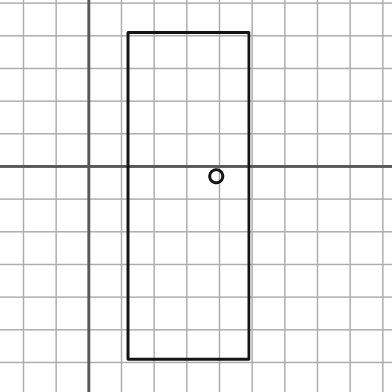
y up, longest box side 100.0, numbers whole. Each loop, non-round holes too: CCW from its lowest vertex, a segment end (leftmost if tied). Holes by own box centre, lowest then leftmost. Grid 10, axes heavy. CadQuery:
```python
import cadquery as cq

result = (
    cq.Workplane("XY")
    .moveTo(12.0, -59.0)
    .lineTo(49.0, -59.0)
    .lineTo(49.0, 41.0)
    .lineTo(12.0, 41.0)
    .close()
    .moveTo(39.0, -3.0)
    .circle(2.0)
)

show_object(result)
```